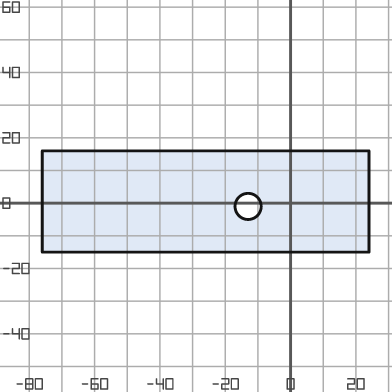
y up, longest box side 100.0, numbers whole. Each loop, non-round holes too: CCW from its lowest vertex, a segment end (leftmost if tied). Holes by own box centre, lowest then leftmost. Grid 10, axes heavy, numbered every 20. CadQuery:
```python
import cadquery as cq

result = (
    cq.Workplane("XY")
    .moveTo(-76.0, -15.0)
    .lineTo(24.0, -15.0)
    .lineTo(24.0, 16.0)
    .lineTo(-76.0, 16.0)
    .close()
    .moveTo(-13.0, -1.0)
    .circle(4.0)
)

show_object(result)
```